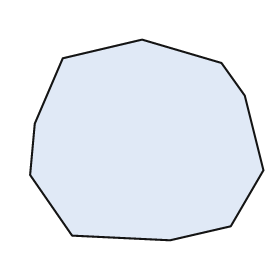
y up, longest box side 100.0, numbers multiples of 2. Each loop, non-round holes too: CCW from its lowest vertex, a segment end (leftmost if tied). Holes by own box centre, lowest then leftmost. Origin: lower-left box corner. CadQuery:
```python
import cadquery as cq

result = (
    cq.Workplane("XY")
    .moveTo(60.0, 0.0)
    .lineTo(86.0, 6.0)
    .lineTo(100.0, 30.0)
    .lineTo(92.0, 62.0)
    .lineTo(82.0, 76.0)
    .lineTo(48.0, 86.0)
    .lineTo(14.0, 78.0)
    .lineTo(2.0, 50.0)
    .lineTo(0.0, 28.0)
    .lineTo(18.0, 2.0)
    .close()
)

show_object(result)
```